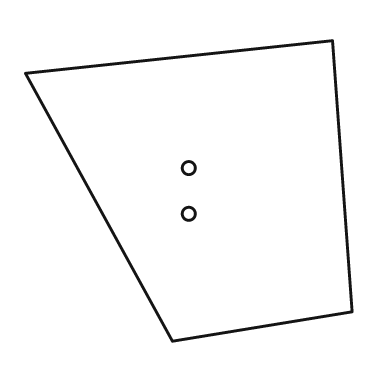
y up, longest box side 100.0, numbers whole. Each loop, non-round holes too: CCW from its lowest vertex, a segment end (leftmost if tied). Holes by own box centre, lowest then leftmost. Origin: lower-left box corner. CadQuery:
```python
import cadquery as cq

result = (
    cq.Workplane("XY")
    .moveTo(45.0, 0.0)
    .lineTo(100.0, 9.0)
    .lineTo(94.0, 92.0)
    .lineTo(0.0, 82.0)
    .close()
    .moveTo(50.0, 39.0)
    .circle(2.0)
    .moveTo(50.0, 53.0)
    .circle(2.0)
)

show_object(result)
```